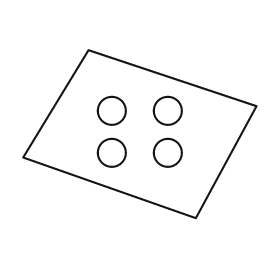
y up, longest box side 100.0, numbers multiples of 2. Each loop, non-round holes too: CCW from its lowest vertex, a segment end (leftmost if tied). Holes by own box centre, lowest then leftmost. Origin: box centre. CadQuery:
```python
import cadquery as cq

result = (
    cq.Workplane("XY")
    .moveTo(24.0, -36.0)
    .lineTo(50.0, 12.0)
    .lineTo(-22.0, 36.0)
    .lineTo(-50.0, -10.0)
    .close()
    .moveTo(-12.0, -8.0)
    .circle(6.0)
    .moveTo(12.0, -8.0)
    .circle(6.0)
    .moveTo(-12.0, 10.0)
    .circle(6.0)
    .moveTo(12.0, 10.0)
    .circle(6.0)
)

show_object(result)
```